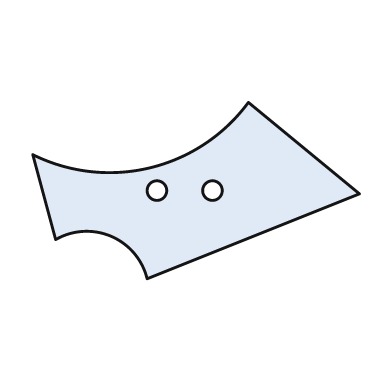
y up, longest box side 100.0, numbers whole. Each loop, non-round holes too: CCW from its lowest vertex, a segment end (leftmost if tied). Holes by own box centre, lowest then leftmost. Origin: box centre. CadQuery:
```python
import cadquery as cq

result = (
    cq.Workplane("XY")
    .moveTo(-15.0, -27.0)
    .lineTo(50.0, -1.0)
    .lineTo(16.0, 27.0)
    .threePointArc((-14.0, 7.0), (-50.0, 11.0))
    .lineTo(-43.0, -15.0)
    .threePointArc((-26.0, -14.0), (-15.0, -27.0))
    .close()
    .moveTo(-12.0, 0.0)
    .circle(3.0)
    .moveTo(5.0, 0.0)
    .circle(3.0)
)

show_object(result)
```